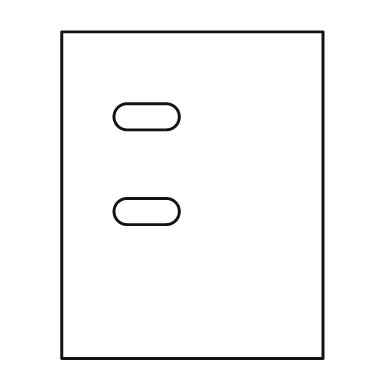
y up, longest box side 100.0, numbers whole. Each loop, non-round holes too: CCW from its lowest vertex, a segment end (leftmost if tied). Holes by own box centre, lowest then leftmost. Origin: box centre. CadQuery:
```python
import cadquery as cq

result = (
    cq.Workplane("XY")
    .moveTo(-40.0, -50.0)
    .lineTo(40.0, -50.0)
    .lineTo(40.0, 50.0)
    .lineTo(-40.0, 50.0)
    .close()
    .moveTo(-20.0, -9.0)
    .lineTo(-8.0, -9.0)
    .threePointArc((-4.0, -5.0), (-8.0, -1.0))
    .lineTo(-20.0, -1.0)
    .threePointArc((-24.0, -5.0), (-20.0, -9.0))
    .close()
    .moveTo(-20.0, 20.0)
    .lineTo(-8.0, 20.0)
    .threePointArc((-4.0, 24.0), (-8.0, 28.0))
    .lineTo(-20.0, 28.0)
    .threePointArc((-24.0, 24.0), (-20.0, 20.0))
    .close()
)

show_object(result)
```